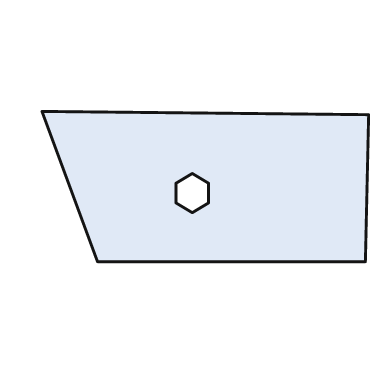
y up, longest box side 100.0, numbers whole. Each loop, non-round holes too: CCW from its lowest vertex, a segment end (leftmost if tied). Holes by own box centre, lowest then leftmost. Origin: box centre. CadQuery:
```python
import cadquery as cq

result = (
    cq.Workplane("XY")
    .moveTo(-33.0, -23.0)
    .lineTo(49.0, -23.0)
    .lineTo(50.0, 22.0)
    .lineTo(-50.0, 23.0)
    .close()
    .moveTo(-4.0, -8.0)
    .lineTo(1.0, -5.0)
    .lineTo(1.0, 1.0)
    .lineTo(-4.0, 4.0)
    .lineTo(-9.0, 1.0)
    .lineTo(-9.0, -5.0)
    .close()
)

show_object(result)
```